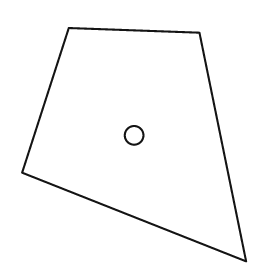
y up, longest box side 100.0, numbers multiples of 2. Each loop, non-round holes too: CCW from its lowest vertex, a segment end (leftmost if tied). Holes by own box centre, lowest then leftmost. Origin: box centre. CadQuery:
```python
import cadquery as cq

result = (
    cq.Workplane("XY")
    .moveTo(48.0, -50.0)
    .lineTo(28.0, 48.0)
    .lineTo(-28.0, 50.0)
    .lineTo(-48.0, -12.0)
    .close()
    .moveTo(0.0, 4.0)
    .circle(4.0)
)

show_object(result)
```